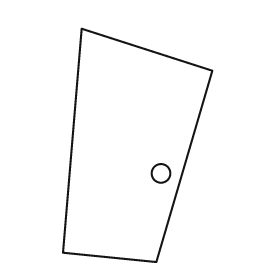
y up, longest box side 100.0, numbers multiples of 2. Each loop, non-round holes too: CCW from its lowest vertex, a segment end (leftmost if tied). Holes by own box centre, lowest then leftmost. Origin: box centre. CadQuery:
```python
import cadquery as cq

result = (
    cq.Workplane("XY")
    .moveTo(8.0, -50.0)
    .lineTo(32.0, 32.0)
    .lineTo(-24.0, 50.0)
    .lineTo(-32.0, -46.0)
    .close()
    .moveTo(10.0, -12.0)
    .circle(4.0)
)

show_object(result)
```